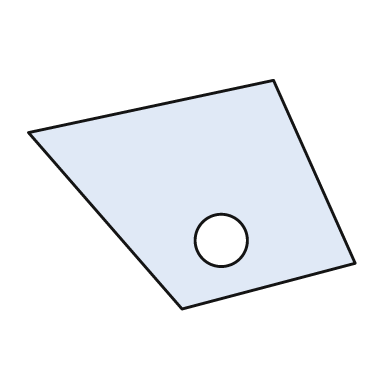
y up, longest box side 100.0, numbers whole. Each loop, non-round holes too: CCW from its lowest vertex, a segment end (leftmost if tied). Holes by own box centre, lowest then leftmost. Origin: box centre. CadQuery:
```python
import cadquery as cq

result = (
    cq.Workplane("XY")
    .moveTo(-3.0, -35.0)
    .lineTo(50.0, -21.0)
    .lineTo(25.0, 35.0)
    .lineTo(-50.0, 19.0)
    .close()
    .moveTo(9.0, -14.0)
    .circle(8.0)
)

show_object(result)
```